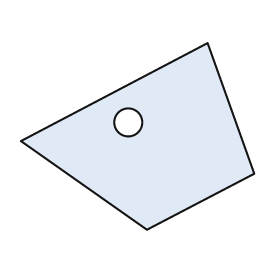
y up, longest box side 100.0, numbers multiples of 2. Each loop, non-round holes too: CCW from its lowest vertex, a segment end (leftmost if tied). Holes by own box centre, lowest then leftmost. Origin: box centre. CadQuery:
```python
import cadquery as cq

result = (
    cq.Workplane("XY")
    .moveTo(4.0, -40.0)
    .lineTo(50.0, -16.0)
    .lineTo(30.0, 40.0)
    .lineTo(-50.0, -2.0)
    .close()
    .moveTo(-4.0, 6.0)
    .circle(6.0)
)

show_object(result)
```